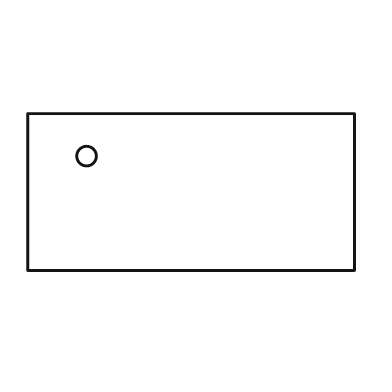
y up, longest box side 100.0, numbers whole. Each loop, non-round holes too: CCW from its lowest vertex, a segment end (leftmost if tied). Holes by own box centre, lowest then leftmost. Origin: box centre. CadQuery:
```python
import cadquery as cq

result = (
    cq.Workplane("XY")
    .moveTo(-50.0, -24.0)
    .lineTo(50.0, -24.0)
    .lineTo(50.0, 24.0)
    .lineTo(-50.0, 24.0)
    .close()
    .moveTo(-32.0, 11.0)
    .circle(3.0)
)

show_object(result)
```